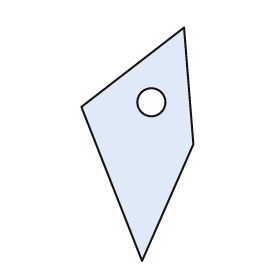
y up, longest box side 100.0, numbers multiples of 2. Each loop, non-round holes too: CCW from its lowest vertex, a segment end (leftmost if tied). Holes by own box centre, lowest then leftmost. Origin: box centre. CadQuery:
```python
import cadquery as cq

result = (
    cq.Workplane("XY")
    .moveTo(2.0, -50.0)
    .lineTo(24.0, 0.0)
    .lineTo(20.0, 50.0)
    .lineTo(-24.0, 16.0)
    .close()
    .moveTo(6.0, 18.0)
    .circle(6.0)
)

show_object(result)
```